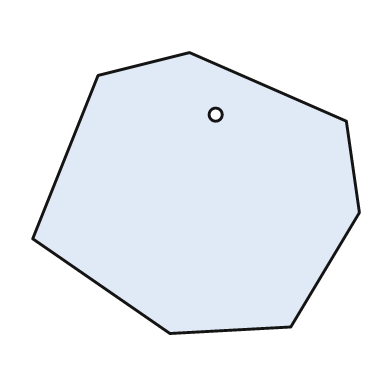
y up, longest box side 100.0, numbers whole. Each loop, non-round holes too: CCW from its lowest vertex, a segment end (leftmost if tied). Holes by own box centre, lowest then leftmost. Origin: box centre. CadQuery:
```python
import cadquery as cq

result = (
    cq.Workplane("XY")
    .moveTo(-8.0, -43.0)
    .lineTo(29.0, -41.0)
    .lineTo(50.0, -6.0)
    .lineTo(46.0, 22.0)
    .lineTo(-2.0, 43.0)
    .lineTo(-30.0, 36.0)
    .lineTo(-50.0, -14.0)
    .close()
    .moveTo(6.0, 24.0)
    .circle(2.0)
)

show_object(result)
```